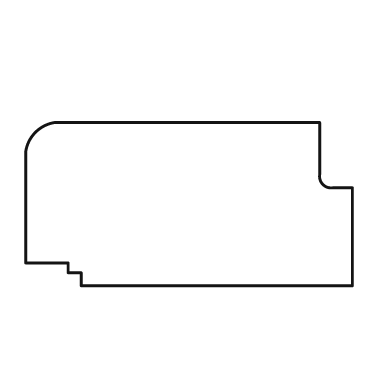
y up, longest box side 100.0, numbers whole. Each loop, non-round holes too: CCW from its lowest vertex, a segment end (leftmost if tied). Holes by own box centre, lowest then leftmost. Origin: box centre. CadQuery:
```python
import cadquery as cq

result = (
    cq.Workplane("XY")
    .moveTo(-33.0, -25.0)
    .lineTo(50.0, -25.0)
    .lineTo(50.0, 5.0)
    .lineTo(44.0, 5.0)
    .threePointArc((41.0, 6.0), (40.0, 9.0))
    .lineTo(40.0, 25.0)
    .lineTo(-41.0, 25.0)
    .threePointArc((-47.0, 22.0), (-50.0, 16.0))
    .lineTo(-50.0, -18.0)
    .lineTo(-37.0, -18.0)
    .lineTo(-37.0, -21.0)
    .lineTo(-33.0, -21.0)
    .close()
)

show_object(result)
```